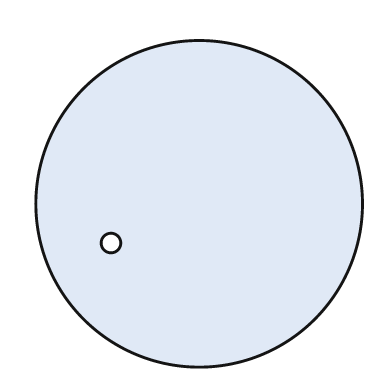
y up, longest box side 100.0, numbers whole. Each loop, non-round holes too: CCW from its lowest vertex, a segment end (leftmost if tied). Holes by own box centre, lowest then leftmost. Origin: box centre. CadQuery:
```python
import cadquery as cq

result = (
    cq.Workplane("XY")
    .moveTo(0.0, 0.0)
    .circle(50.0)
    .moveTo(-27.0, -12.0)
    .circle(3.0)
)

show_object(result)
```